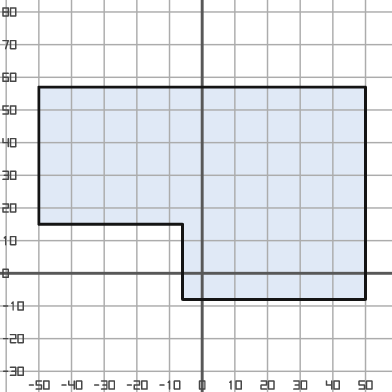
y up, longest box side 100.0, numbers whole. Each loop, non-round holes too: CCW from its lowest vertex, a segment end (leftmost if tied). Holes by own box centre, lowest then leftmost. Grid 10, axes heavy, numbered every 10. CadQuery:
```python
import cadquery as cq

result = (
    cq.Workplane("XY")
    .moveTo(-6.0, -8.0)
    .lineTo(50.0, -8.0)
    .lineTo(50.0, 57.0)
    .lineTo(-50.0, 57.0)
    .lineTo(-50.0, 15.0)
    .lineTo(-6.0, 15.0)
    .close()
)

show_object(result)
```